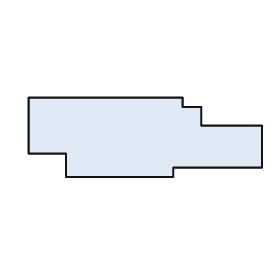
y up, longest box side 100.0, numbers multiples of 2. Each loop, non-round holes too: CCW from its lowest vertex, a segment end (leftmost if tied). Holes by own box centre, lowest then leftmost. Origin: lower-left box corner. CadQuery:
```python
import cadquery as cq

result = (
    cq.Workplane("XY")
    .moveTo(16.0, 0.0)
    .lineTo(62.0, 0.0)
    .lineTo(62.0, 4.0)
    .lineTo(100.0, 4.0)
    .lineTo(100.0, 22.0)
    .lineTo(74.0, 22.0)
    .lineTo(74.0, 30.0)
    .lineTo(66.0, 30.0)
    .lineTo(66.0, 34.0)
    .lineTo(0.0, 34.0)
    .lineTo(0.0, 10.0)
    .lineTo(16.0, 10.0)
    .close()
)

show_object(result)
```